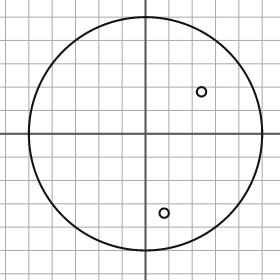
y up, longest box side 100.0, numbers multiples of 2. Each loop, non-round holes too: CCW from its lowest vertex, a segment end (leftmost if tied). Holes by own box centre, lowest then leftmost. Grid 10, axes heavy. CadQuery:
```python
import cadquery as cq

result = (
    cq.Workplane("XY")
    .moveTo(0.0, 0.0)
    .circle(50.0)
    .moveTo(8.0, -34.0)
    .circle(2.0)
    .moveTo(24.0, 18.0)
    .circle(2.0)
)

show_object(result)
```